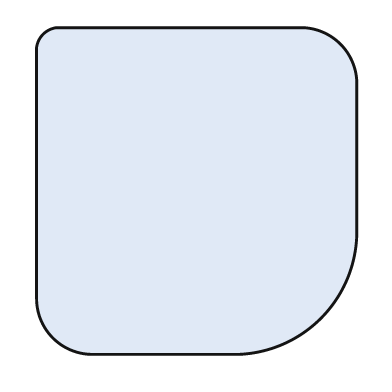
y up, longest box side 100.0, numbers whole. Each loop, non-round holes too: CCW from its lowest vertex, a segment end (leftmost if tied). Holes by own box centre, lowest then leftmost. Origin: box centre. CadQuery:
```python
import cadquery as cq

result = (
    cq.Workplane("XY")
    .moveTo(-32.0, -50.0)
    .lineTo(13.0, -50.0)
    .threePointArc((38.0, -39.0), (49.0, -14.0))
    .lineTo(49.0, 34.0)
    .threePointArc((44.0, 45.0), (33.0, 50.0))
    .lineTo(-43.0, 50.0)
    .threePointArc((-47.0, 48.0), (-49.0, 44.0))
    .lineTo(-49.0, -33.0)
    .threePointArc((-44.0, -45.0), (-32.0, -50.0))
    .close()
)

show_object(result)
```